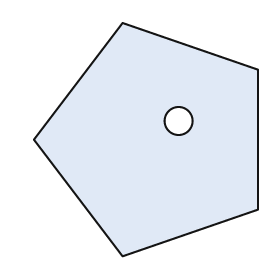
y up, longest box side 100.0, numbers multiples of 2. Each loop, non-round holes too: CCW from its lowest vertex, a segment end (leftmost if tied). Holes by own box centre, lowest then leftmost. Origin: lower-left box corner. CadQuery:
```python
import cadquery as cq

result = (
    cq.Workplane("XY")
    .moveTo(38.0, 0.0)
    .lineTo(96.0, 20.0)
    .lineTo(96.0, 80.0)
    .lineTo(38.0, 100.0)
    .lineTo(0.0, 50.0)
    .close()
    .moveTo(62.0, 58.0)
    .circle(6.0)
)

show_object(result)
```